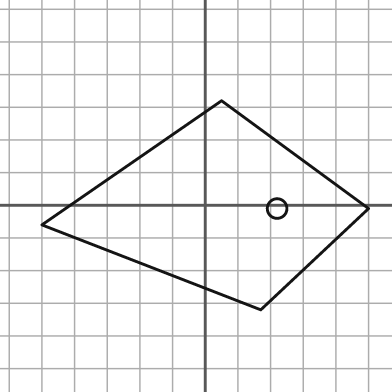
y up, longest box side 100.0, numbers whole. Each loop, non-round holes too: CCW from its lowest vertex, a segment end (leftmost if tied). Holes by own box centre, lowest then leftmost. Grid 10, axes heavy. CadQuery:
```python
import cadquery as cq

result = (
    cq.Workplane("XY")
    .moveTo(17.0, -32.0)
    .lineTo(50.0, -1.0)
    .lineTo(5.0, 32.0)
    .lineTo(-50.0, -6.0)
    .close()
    .moveTo(22.0, -1.0)
    .circle(3.0)
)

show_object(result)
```